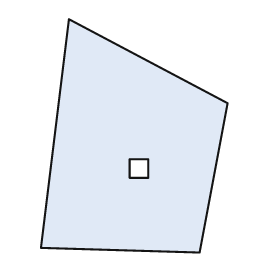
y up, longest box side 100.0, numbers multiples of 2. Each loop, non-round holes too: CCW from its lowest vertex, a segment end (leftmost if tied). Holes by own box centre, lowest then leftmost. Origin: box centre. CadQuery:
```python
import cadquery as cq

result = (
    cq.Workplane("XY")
    .moveTo(28.0, -50.0)
    .lineTo(40.0, 14.0)
    .lineTo(-28.0, 50.0)
    .lineTo(-40.0, -48.0)
    .close()
    .moveTo(-2.0, -18.0)
    .lineTo(6.0, -18.0)
    .lineTo(6.0, -10.0)
    .lineTo(-2.0, -10.0)
    .close()
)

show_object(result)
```